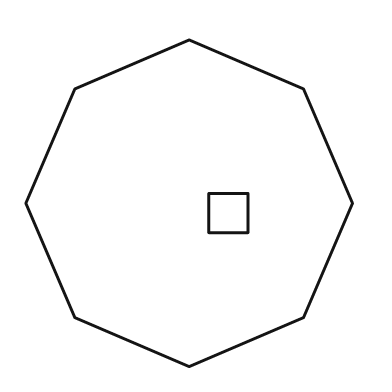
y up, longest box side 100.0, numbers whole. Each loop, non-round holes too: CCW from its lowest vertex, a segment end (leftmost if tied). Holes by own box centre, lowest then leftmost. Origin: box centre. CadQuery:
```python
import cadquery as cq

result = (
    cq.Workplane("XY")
    .moveTo(0.0, -50.0)
    .lineTo(35.0, -35.0)
    .lineTo(50.0, 0.0)
    .lineTo(35.0, 35.0)
    .lineTo(0.0, 50.0)
    .lineTo(-35.0, 35.0)
    .lineTo(-50.0, 0.0)
    .lineTo(-35.0, -35.0)
    .close()
    .moveTo(6.0, -9.0)
    .lineTo(18.0, -9.0)
    .lineTo(18.0, 3.0)
    .lineTo(6.0, 3.0)
    .close()
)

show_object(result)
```